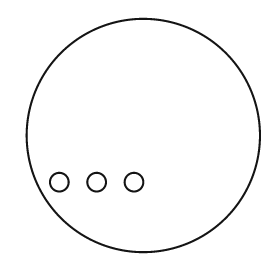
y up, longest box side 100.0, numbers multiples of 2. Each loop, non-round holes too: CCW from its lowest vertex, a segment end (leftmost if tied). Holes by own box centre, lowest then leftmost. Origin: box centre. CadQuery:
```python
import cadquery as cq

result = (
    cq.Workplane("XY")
    .moveTo(0.0, 0.0)
    .circle(50.0)
    .moveTo(-36.0, -20.0)
    .circle(4.0)
    .moveTo(-20.0, -20.0)
    .circle(4.0)
    .moveTo(-4.0, -20.0)
    .circle(4.0)
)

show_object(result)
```